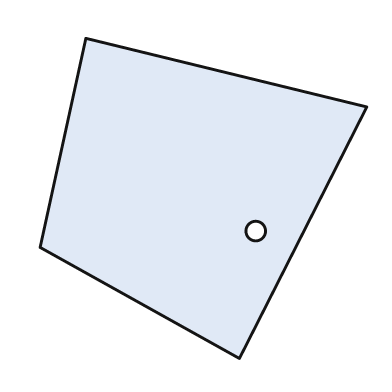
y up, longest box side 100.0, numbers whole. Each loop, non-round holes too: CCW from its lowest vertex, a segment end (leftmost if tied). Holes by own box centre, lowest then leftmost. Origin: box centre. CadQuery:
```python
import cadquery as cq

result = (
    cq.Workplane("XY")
    .moveTo(11.0, -49.0)
    .lineTo(50.0, 28.0)
    .lineTo(-36.0, 49.0)
    .lineTo(-50.0, -15.0)
    .close()
    .moveTo(16.0, -10.0)
    .circle(3.0)
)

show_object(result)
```